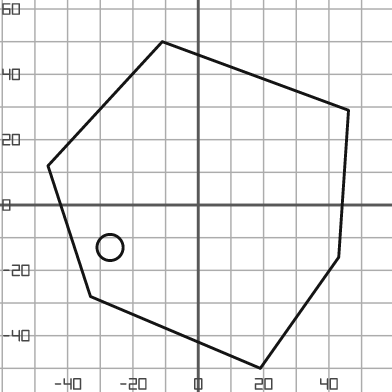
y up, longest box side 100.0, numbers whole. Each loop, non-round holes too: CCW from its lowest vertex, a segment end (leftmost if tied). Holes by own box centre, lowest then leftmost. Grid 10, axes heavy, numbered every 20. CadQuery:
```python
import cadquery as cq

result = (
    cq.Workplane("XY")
    .moveTo(19.0, -50.0)
    .lineTo(43.0, -16.0)
    .lineTo(46.0, 29.0)
    .lineTo(-11.0, 50.0)
    .lineTo(-46.0, 12.0)
    .lineTo(-33.0, -28.0)
    .close()
    .moveTo(-27.0, -13.0)
    .circle(4.0)
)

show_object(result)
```